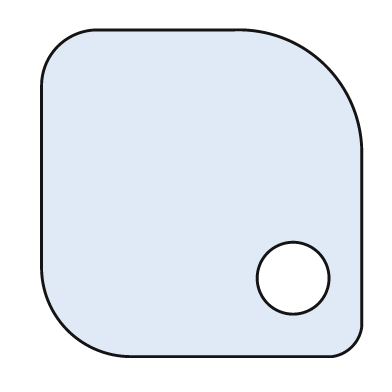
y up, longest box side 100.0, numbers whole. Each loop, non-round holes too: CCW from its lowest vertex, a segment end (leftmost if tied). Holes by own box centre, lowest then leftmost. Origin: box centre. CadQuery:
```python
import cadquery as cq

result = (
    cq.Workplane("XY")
    .moveTo(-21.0, -50.0)
    .lineTo(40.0, -50.0)
    .threePointArc((46.0, -47.0), (49.0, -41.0))
    .lineTo(49.0, 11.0)
    .threePointArc((38.0, 39.0), (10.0, 50.0))
    .lineTo(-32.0, 50.0)
    .threePointArc((-44.0, 45.0), (-49.0, 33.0))
    .lineTo(-49.0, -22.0)
    .threePointArc((-41.0, -42.0), (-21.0, -50.0))
    .close()
    .moveTo(28.0, -26.0)
    .circle(11.0)
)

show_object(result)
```